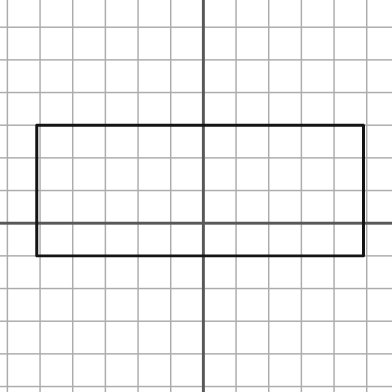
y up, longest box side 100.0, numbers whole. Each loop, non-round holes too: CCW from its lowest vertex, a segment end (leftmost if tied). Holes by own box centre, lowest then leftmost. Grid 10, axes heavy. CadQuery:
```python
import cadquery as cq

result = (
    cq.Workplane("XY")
    .moveTo(-51.0, -10.0)
    .lineTo(49.0, -10.0)
    .lineTo(49.0, 30.0)
    .lineTo(-51.0, 30.0)
    .close()
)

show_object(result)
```